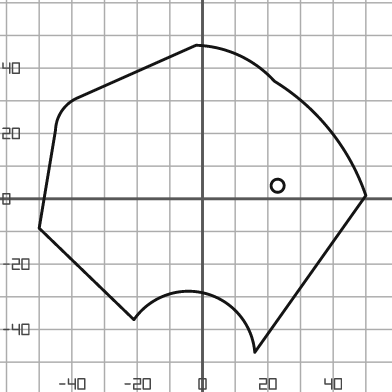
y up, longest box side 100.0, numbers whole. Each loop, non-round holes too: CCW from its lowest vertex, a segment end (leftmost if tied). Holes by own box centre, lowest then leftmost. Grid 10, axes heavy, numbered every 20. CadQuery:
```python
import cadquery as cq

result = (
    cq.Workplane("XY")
    .moveTo(16.0, -47.0)
    .lineTo(50.0, 1.0)
    .threePointArc((39.0, 21.0), (22.0, 36.0))
    .threePointArc((11.0, 44.0), (-2.0, 47.0))
    .lineTo(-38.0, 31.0)
    .threePointArc((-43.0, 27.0), (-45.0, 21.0))
    .lineTo(-50.0, -9.0)
    .lineTo(-21.0, -37.0)
    .threePointArc((1.0, -29.0), (16.0, -47.0))
    .close()
    .moveTo(23.0, 4.0)
    .circle(2.0)
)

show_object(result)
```